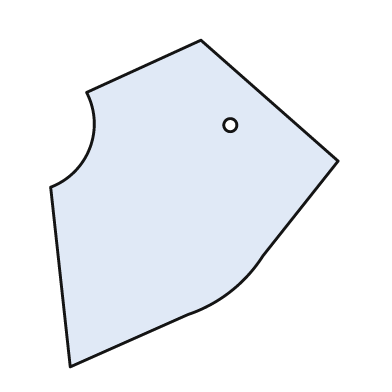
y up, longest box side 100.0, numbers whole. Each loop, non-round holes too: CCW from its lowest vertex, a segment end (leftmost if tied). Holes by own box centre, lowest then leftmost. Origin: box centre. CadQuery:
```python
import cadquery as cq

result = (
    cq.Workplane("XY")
    .moveTo(-38.0, -50.0)
    .lineTo(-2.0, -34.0)
    .threePointArc((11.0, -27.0), (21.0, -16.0))
    .lineTo(44.0, 13.0)
    .lineTo(2.0, 50.0)
    .lineTo(-33.0, 34.0)
    .threePointArc((-32.0, 17.0), (-44.0, 5.0))
    .close()
    .moveTo(11.0, 24.0)
    .circle(2.0)
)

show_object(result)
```